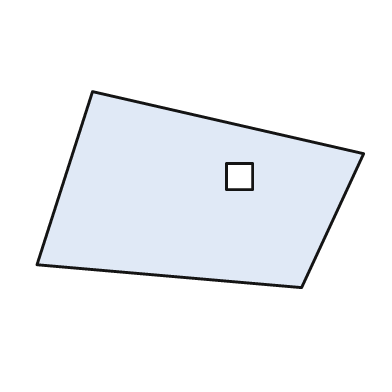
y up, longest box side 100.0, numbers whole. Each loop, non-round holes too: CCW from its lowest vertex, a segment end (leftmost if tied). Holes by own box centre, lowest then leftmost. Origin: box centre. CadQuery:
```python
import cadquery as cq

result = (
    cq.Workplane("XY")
    .moveTo(31.0, -30.0)
    .lineTo(50.0, 11.0)
    .lineTo(-33.0, 30.0)
    .lineTo(-50.0, -23.0)
    .close()
    .moveTo(8.0, 0.0)
    .lineTo(16.0, 0.0)
    .lineTo(16.0, 8.0)
    .lineTo(8.0, 8.0)
    .close()
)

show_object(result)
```